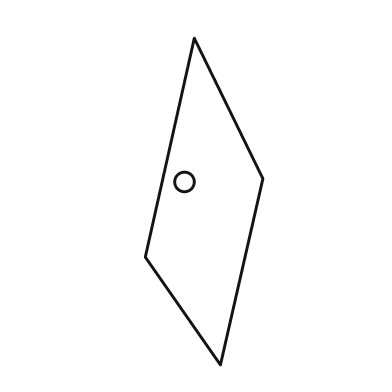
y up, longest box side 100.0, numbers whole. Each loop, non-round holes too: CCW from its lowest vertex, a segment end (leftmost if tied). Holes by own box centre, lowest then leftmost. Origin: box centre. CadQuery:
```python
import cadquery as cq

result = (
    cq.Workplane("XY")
    .moveTo(5.0, -50.0)
    .lineTo(18.0, 7.0)
    .lineTo(-3.0, 50.0)
    .lineTo(-18.0, -17.0)
    .close()
    .moveTo(-6.0, 6.0)
    .circle(3.0)
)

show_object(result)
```